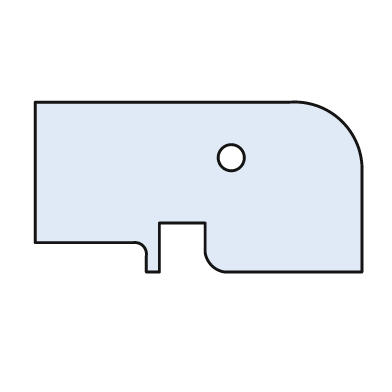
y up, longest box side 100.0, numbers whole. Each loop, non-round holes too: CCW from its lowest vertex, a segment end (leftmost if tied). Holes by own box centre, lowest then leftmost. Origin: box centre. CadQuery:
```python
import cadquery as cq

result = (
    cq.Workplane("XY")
    .moveTo(-16.0, -26.0)
    .lineTo(-12.0, -26.0)
    .lineTo(-12.0, -11.0)
    .lineTo(2.0, -11.0)
    .lineTo(2.0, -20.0)
    .threePointArc((4.0, -24.0), (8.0, -26.0))
    .lineTo(50.0, -26.0)
    .lineTo(50.0, 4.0)
    .threePointArc((44.0, 20.0), (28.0, 26.0))
    .lineTo(-50.0, 26.0)
    .lineTo(-50.0, -17.0)
    .lineTo(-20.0, -17.0)
    .threePointArc((-17.0, -18.0), (-16.0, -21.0))
    .close()
    .moveTo(10.0, 9.0)
    .circle(4.0)
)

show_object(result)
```